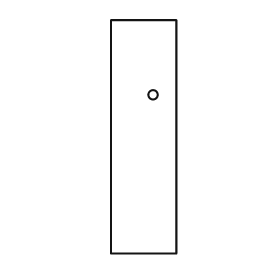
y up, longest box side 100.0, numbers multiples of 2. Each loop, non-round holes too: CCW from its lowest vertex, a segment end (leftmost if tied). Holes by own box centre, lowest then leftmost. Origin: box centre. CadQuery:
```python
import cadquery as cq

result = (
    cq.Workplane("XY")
    .moveTo(-14.0, -50.0)
    .lineTo(14.0, -50.0)
    .lineTo(14.0, 50.0)
    .lineTo(-14.0, 50.0)
    .close()
    .moveTo(4.0, 18.0)
    .circle(2.0)
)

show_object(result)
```